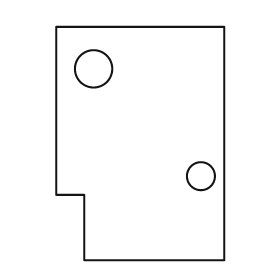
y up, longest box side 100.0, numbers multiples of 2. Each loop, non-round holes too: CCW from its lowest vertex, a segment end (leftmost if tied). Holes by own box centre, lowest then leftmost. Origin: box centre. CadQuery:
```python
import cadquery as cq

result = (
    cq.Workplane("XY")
    .moveTo(-24.0, -50.0)
    .lineTo(36.0, -50.0)
    .lineTo(36.0, 50.0)
    .lineTo(-36.0, 50.0)
    .lineTo(-36.0, -22.0)
    .lineTo(-24.0, -22.0)
    .close()
    .moveTo(26.0, -14.0)
    .circle(6.0)
    .moveTo(-20.0, 32.0)
    .circle(8.0)
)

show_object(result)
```